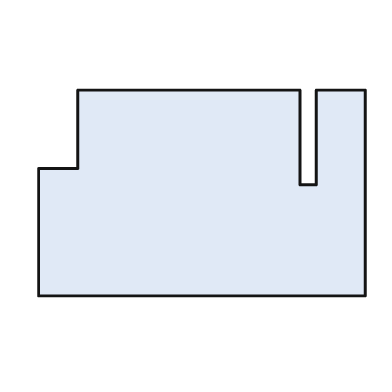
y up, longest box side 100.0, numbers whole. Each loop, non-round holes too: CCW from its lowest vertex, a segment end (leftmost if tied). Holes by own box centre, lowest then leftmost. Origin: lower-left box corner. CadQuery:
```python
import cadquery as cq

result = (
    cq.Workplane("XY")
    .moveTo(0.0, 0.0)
    .lineTo(100.0, 0.0)
    .lineTo(100.0, 63.0)
    .lineTo(85.0, 63.0)
    .lineTo(85.0, 34.0)
    .lineTo(80.0, 34.0)
    .lineTo(80.0, 63.0)
    .lineTo(12.0, 63.0)
    .lineTo(12.0, 39.0)
    .lineTo(0.0, 39.0)
    .close()
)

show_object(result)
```